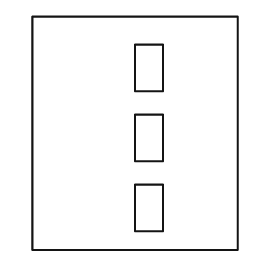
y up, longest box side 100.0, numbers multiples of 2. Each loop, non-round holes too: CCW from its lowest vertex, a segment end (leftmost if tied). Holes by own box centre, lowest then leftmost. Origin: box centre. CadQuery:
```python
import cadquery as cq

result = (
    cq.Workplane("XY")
    .moveTo(-44.0, -50.0)
    .lineTo(44.0, -50.0)
    .lineTo(44.0, 50.0)
    .lineTo(-44.0, 50.0)
    .close()
    .moveTo(0.0, -42.0)
    .lineTo(12.0, -42.0)
    .lineTo(12.0, -22.0)
    .lineTo(0.0, -22.0)
    .close()
    .moveTo(0.0, -12.0)
    .lineTo(12.0, -12.0)
    .lineTo(12.0, 8.0)
    .lineTo(0.0, 8.0)
    .close()
    .moveTo(0.0, 18.0)
    .lineTo(12.0, 18.0)
    .lineTo(12.0, 38.0)
    .lineTo(0.0, 38.0)
    .close()
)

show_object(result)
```